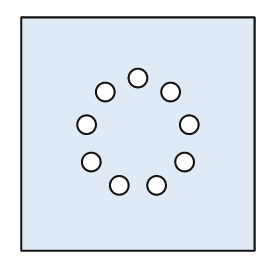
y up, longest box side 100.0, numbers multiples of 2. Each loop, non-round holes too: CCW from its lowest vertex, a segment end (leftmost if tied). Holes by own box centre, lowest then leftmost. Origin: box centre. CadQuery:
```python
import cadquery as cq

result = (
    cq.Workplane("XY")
    .moveTo(-50.0, -50.0)
    .lineTo(50.0, -50.0)
    .lineTo(50.0, 50.0)
    .lineTo(-50.0, 50.0)
    .close()
    .moveTo(-8.0, -22.0)
    .circle(4.0)
    .moveTo(8.0, -22.0)
    .circle(4.0)
    .moveTo(-20.0, -12.0)
    .circle(4.0)
    .moveTo(20.0, -12.0)
    .circle(4.0)
    .moveTo(-22.0, 4.0)
    .circle(4.0)
    .moveTo(22.0, 4.0)
    .circle(4.0)
    .moveTo(-14.0, 18.0)
    .circle(4.0)
    .moveTo(14.0, 18.0)
    .circle(4.0)
    .moveTo(0.0, 24.0)
    .circle(4.0)
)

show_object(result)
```